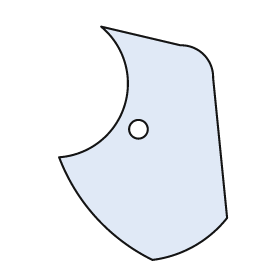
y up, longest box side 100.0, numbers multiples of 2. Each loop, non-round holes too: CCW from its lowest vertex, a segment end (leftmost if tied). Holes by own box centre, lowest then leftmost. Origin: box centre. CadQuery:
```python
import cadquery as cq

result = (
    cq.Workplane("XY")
    .moveTo(4.0, -50.0)
    .threePointArc((22.0, -44.0), (36.0, -32.0))
    .lineTo(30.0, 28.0)
    .threePointArc((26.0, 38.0), (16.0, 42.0))
    .lineTo(-18.0, 50.0)
    .threePointArc((-8.0, 16.0), (-36.0, -6.0))
    .threePointArc((-20.0, -32.0), (4.0, -50.0))
    .close()
    .moveTo(-2.0, 6.0)
    .circle(4.0)
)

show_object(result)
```